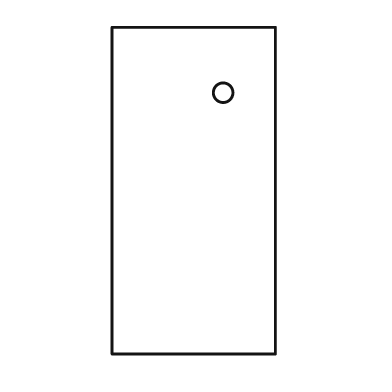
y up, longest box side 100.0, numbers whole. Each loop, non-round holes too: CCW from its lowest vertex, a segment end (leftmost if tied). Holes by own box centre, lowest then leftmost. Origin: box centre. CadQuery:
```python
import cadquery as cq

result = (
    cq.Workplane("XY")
    .moveTo(-25.0, -50.0)
    .lineTo(25.0, -50.0)
    .lineTo(25.0, 50.0)
    .lineTo(-25.0, 50.0)
    .close()
    .moveTo(9.0, 30.0)
    .circle(3.0)
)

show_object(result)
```